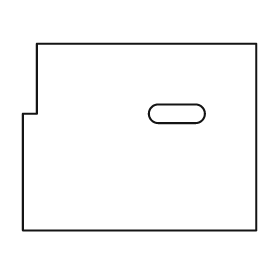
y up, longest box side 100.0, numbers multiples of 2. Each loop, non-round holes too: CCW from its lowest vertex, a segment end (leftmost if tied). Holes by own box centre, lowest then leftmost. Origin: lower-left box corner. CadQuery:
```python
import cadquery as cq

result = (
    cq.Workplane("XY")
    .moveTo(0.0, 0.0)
    .lineTo(100.0, 0.0)
    .lineTo(100.0, 80.0)
    .lineTo(6.0, 80.0)
    .lineTo(6.0, 50.0)
    .lineTo(0.0, 50.0)
    .close()
    .moveTo(58.0, 46.0)
    .lineTo(74.0, 46.0)
    .threePointArc((78.0, 50.0), (74.0, 54.0))
    .lineTo(58.0, 54.0)
    .threePointArc((54.0, 50.0), (58.0, 46.0))
    .close()
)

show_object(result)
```